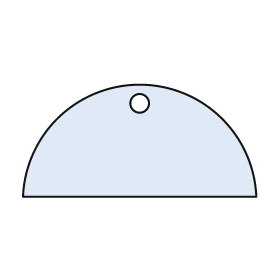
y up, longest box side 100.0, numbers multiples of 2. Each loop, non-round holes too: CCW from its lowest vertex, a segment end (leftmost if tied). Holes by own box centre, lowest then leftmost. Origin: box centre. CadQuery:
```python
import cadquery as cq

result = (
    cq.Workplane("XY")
    .moveTo(-50.0, -24.0)
    .lineTo(50.0, -24.0)
    .threePointArc((0.0, 24.0), (-50.0, -24.0))
    .close()
    .moveTo(0.0, 16.0)
    .circle(4.0)
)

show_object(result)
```